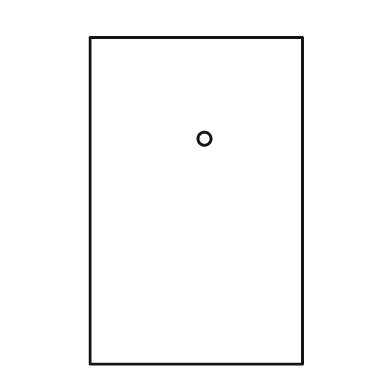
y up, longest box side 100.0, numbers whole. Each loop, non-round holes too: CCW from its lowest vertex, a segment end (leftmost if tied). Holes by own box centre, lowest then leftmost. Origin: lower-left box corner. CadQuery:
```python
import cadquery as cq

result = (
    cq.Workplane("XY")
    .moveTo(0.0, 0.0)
    .lineTo(65.0, 0.0)
    .lineTo(65.0, 100.0)
    .lineTo(0.0, 100.0)
    .close()
    .moveTo(35.0, 69.0)
    .circle(2.0)
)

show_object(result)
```